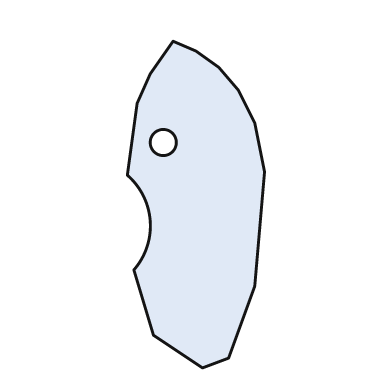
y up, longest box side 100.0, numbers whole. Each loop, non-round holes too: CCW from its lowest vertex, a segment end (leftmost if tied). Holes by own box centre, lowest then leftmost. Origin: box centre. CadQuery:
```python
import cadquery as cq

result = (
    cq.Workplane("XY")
    .moveTo(2.0, -50.0)
    .lineTo(10.0, -47.0)
    .lineTo(18.0, -25.0)
    .lineTo(21.0, 10.0)
    .lineTo(18.0, 25.0)
    .lineTo(13.0, 35.0)
    .lineTo(7.0, 42.0)
    .lineTo(0.0, 47.0)
    .lineTo(-7.0, 50.0)
    .lineTo(-14.0, 40.0)
    .lineTo(-18.0, 31.0)
    .lineTo(-21.0, 9.0)
    .threePointArc((-14.0, -5.0), (-19.0, -20.0))
    .lineTo(-13.0, -40.0)
    .close()
    .moveTo(-10.0, 19.0)
    .circle(4.0)
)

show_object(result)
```